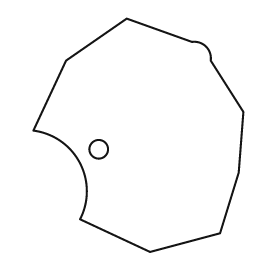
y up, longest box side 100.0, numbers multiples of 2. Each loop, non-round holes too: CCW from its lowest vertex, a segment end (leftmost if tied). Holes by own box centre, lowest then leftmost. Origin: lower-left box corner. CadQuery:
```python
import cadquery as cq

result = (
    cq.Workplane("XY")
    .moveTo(50.0, 0.0)
    .lineTo(80.0, 8.0)
    .lineTo(88.0, 34.0)
    .lineTo(90.0, 60.0)
    .lineTo(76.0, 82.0)
    .threePointArc((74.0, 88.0), (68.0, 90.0))
    .lineTo(40.0, 100.0)
    .lineTo(14.0, 82.0)
    .lineTo(0.0, 52.0)
    .threePointArc((20.0, 38.0), (20.0, 14.0))
    .close()
    .moveTo(28.0, 44.0)
    .circle(4.0)
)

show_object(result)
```